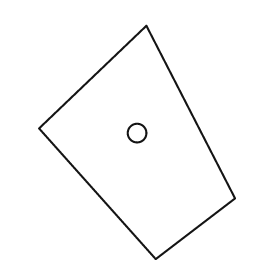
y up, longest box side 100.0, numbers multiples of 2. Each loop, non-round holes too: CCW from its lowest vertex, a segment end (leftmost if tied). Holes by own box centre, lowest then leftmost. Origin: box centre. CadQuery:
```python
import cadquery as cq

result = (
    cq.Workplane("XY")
    .moveTo(8.0, -50.0)
    .lineTo(42.0, -24.0)
    .lineTo(4.0, 50.0)
    .lineTo(-42.0, 6.0)
    .close()
    .moveTo(0.0, 4.0)
    .circle(4.0)
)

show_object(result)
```